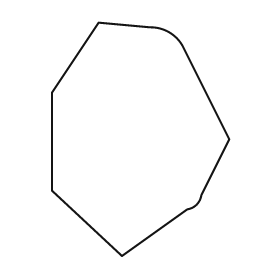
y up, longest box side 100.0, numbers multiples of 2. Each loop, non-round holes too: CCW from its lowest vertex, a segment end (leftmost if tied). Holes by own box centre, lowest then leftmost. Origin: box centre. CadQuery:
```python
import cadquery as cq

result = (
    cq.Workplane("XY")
    .moveTo(-8.0, -50.0)
    .lineTo(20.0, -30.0)
    .threePointArc((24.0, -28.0), (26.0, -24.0))
    .lineTo(38.0, 0.0)
    .lineTo(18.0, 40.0)
    .threePointArc((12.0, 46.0), (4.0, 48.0))
    .lineTo(-18.0, 50.0)
    .lineTo(-38.0, 20.0)
    .lineTo(-38.0, -22.0)
    .close()
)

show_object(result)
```